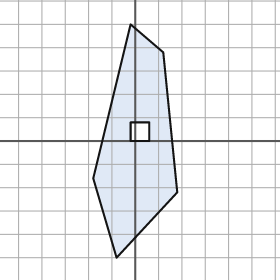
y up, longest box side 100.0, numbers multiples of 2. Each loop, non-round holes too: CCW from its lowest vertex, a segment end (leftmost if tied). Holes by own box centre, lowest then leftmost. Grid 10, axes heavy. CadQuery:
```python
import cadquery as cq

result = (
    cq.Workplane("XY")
    .moveTo(-8.0, -50.0)
    .lineTo(18.0, -22.0)
    .lineTo(12.0, 38.0)
    .lineTo(-2.0, 50.0)
    .lineTo(-18.0, -16.0)
    .close()
    .moveTo(-2.0, 0.0)
    .lineTo(6.0, 0.0)
    .lineTo(6.0, 8.0)
    .lineTo(-2.0, 8.0)
    .close()
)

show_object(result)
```